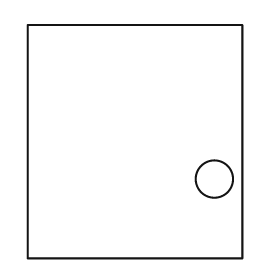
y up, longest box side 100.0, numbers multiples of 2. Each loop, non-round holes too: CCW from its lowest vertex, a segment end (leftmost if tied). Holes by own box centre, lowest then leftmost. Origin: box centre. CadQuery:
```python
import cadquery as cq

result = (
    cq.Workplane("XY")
    .moveTo(-46.0, -50.0)
    .lineTo(46.0, -50.0)
    .lineTo(46.0, 50.0)
    .lineTo(-46.0, 50.0)
    .close()
    .moveTo(34.0, -16.0)
    .circle(8.0)
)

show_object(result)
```